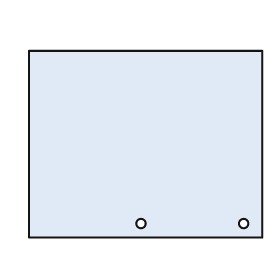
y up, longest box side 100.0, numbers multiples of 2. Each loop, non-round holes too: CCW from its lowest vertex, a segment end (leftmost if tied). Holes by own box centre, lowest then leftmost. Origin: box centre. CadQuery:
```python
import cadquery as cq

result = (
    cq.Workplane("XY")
    .moveTo(-50.0, -40.0)
    .lineTo(50.0, -40.0)
    .lineTo(50.0, 40.0)
    .lineTo(-50.0, 40.0)
    .close()
    .moveTo(-2.0, -34.0)
    .circle(2.0)
    .moveTo(42.0, -34.0)
    .circle(2.0)
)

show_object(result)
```